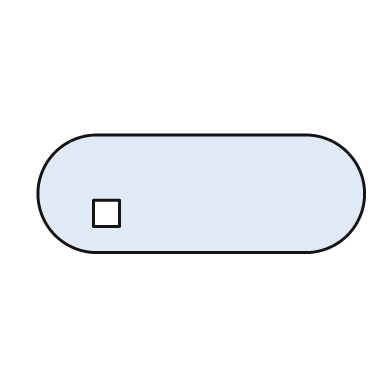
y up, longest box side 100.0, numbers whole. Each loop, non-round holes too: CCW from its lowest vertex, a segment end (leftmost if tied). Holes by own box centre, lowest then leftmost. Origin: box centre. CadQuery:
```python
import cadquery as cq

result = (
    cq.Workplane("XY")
    .moveTo(-32.0, -18.0)
    .lineTo(32.0, -18.0)
    .threePointArc((50.0, 0.0), (32.0, 18.0))
    .lineTo(-32.0, 18.0)
    .threePointArc((-50.0, 0.0), (-32.0, -18.0))
    .close()
    .moveTo(-33.0, -10.0)
    .lineTo(-25.0, -10.0)
    .lineTo(-25.0, -2.0)
    .lineTo(-33.0, -2.0)
    .close()
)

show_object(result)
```